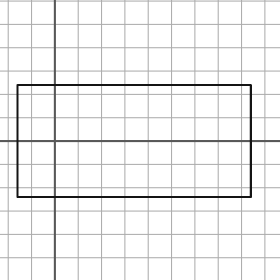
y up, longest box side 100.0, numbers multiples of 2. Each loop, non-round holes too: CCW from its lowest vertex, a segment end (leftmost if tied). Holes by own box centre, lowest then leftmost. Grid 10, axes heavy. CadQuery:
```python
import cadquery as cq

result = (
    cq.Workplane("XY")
    .moveTo(-16.0, -24.0)
    .lineTo(84.0, -24.0)
    .lineTo(84.0, 24.0)
    .lineTo(-16.0, 24.0)
    .close()
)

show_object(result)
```